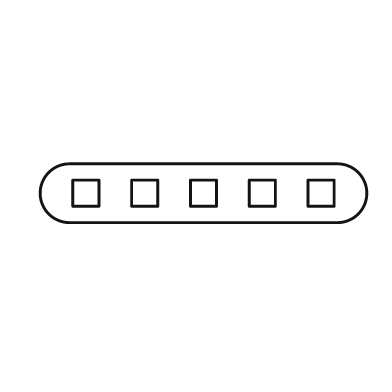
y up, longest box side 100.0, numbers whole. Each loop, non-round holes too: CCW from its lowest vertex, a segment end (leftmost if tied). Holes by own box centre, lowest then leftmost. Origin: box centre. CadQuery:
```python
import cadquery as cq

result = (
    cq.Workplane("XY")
    .moveTo(-41.0, -9.0)
    .lineTo(41.0, -9.0)
    .threePointArc((50.0, 0.0), (41.0, 9.0))
    .lineTo(-41.0, 9.0)
    .threePointArc((-50.0, 0.0), (-41.0, -9.0))
    .close()
    .moveTo(-40.0, -4.0)
    .lineTo(-32.0, -4.0)
    .lineTo(-32.0, 4.0)
    .lineTo(-40.0, 4.0)
    .close()
    .moveTo(-22.0, -4.0)
    .lineTo(-14.0, -4.0)
    .lineTo(-14.0, 4.0)
    .lineTo(-22.0, 4.0)
    .close()
    .moveTo(-4.0, -4.0)
    .lineTo(4.0, -4.0)
    .lineTo(4.0, 4.0)
    .lineTo(-4.0, 4.0)
    .close()
    .moveTo(14.0, -4.0)
    .lineTo(22.0, -4.0)
    .lineTo(22.0, 4.0)
    .lineTo(14.0, 4.0)
    .close()
    .moveTo(32.0, -4.0)
    .lineTo(40.0, -4.0)
    .lineTo(40.0, 4.0)
    .lineTo(32.0, 4.0)
    .close()
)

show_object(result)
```